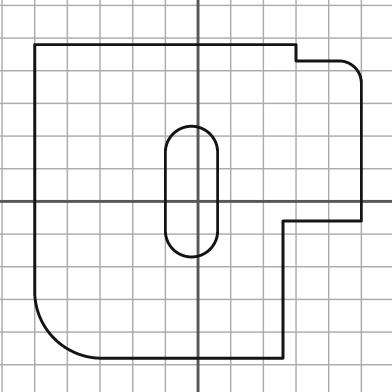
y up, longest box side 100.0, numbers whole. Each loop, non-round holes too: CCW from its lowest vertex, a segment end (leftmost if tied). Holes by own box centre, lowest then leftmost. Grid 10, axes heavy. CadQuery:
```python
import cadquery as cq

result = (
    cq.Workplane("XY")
    .moveTo(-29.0, -48.0)
    .lineTo(26.0, -48.0)
    .lineTo(26.0, -6.0)
    .lineTo(50.0, -6.0)
    .lineTo(50.0, 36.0)
    .threePointArc((48.0, 41.0), (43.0, 43.0))
    .lineTo(30.0, 43.0)
    .lineTo(30.0, 48.0)
    .lineTo(-50.0, 48.0)
    .lineTo(-50.0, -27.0)
    .threePointArc((-44.0, -42.0), (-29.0, -48.0))
    .close()
    .moveTo(-10.0, -9.0)
    .threePointArc((-2.0, -17.0), (6.0, -9.0))
    .lineTo(6.0, 15.0)
    .threePointArc((-2.0, 23.0), (-10.0, 15.0))
    .close()
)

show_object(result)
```